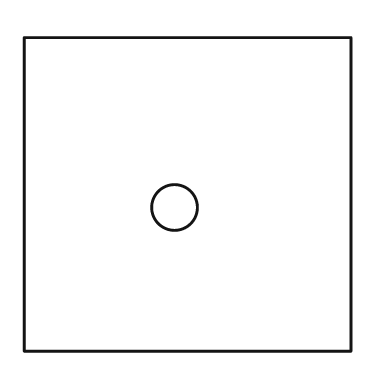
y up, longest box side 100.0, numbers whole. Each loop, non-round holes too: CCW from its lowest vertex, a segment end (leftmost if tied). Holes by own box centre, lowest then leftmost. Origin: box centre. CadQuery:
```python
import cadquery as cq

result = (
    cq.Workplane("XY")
    .moveTo(-50.0, -48.0)
    .lineTo(50.0, -48.0)
    .lineTo(50.0, 48.0)
    .lineTo(-50.0, 48.0)
    .close()
    .moveTo(-4.0, -4.0)
    .circle(7.0)
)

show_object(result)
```